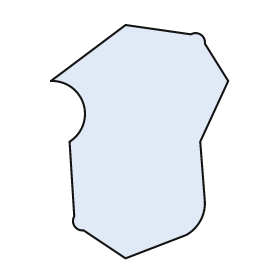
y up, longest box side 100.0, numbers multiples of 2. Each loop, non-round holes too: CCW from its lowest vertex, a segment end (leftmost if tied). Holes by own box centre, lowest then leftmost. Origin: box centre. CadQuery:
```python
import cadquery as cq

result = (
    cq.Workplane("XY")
    .moveTo(-6.0, -50.0)
    .lineTo(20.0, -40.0)
    .threePointArc((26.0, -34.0), (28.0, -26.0))
    .lineTo(26.0, 0.0)
    .lineTo(38.0, 26.0)
    .lineTo(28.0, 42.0)
    .threePointArc((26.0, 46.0), (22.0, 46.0))
    .lineTo(-6.0, 50.0)
    .lineTo(-38.0, 26.0)
    .threePointArc((-24.0, 16.0), (-30.0, 0.0))
    .lineTo(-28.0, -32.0)
    .threePointArc((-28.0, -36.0), (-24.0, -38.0))
    .close()
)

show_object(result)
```